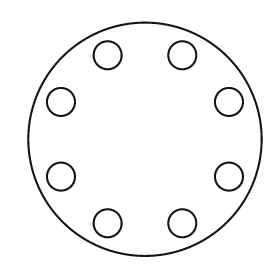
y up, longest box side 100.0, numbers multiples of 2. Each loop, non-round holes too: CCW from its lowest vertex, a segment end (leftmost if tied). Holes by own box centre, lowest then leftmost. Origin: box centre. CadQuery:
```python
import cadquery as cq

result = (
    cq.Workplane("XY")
    .moveTo(0.0, 0.0)
    .circle(50.0)
    .moveTo(-16.0, -36.0)
    .circle(6.0)
    .moveTo(16.0, -36.0)
    .circle(6.0)
    .moveTo(-36.0, -16.0)
    .circle(6.0)
    .moveTo(36.0, -16.0)
    .circle(6.0)
    .moveTo(-36.0, 16.0)
    .circle(6.0)
    .moveTo(36.0, 16.0)
    .circle(6.0)
    .moveTo(-16.0, 36.0)
    .circle(6.0)
    .moveTo(16.0, 36.0)
    .circle(6.0)
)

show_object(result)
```